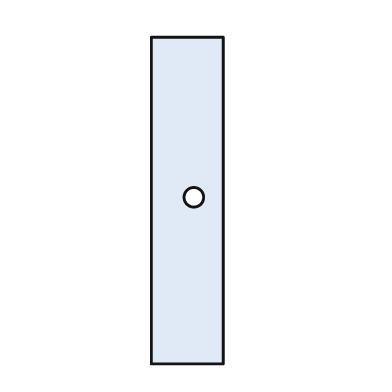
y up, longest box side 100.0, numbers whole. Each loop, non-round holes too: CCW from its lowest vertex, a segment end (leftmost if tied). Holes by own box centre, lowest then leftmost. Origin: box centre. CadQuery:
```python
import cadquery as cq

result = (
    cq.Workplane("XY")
    .moveTo(-11.0, -50.0)
    .lineTo(11.0, -50.0)
    .lineTo(11.0, 50.0)
    .lineTo(-11.0, 50.0)
    .close()
    .moveTo(2.0, 1.0)
    .circle(3.0)
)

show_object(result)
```